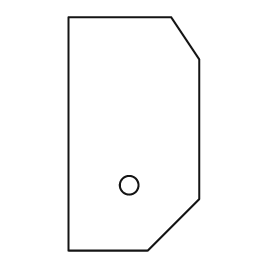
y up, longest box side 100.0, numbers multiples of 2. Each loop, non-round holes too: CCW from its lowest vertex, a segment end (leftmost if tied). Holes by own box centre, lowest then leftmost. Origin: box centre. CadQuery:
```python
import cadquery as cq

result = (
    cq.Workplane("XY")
    .moveTo(-28.0, -50.0)
    .lineTo(6.0, -50.0)
    .lineTo(28.0, -28.0)
    .lineTo(28.0, 32.0)
    .lineTo(16.0, 50.0)
    .lineTo(-28.0, 50.0)
    .close()
    .moveTo(-2.0, -22.0)
    .circle(4.0)
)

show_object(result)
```